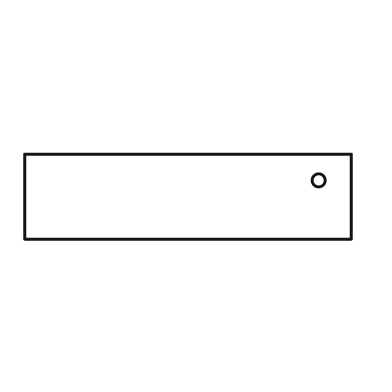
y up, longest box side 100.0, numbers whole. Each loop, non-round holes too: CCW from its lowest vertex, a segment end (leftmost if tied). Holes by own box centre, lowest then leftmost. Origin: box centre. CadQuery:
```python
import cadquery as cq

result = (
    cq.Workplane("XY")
    .moveTo(-50.0, -13.0)
    .lineTo(50.0, -13.0)
    .lineTo(50.0, 13.0)
    .lineTo(-50.0, 13.0)
    .close()
    .moveTo(40.0, 5.0)
    .circle(2.0)
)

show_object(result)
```